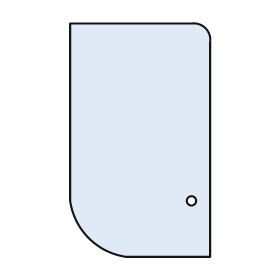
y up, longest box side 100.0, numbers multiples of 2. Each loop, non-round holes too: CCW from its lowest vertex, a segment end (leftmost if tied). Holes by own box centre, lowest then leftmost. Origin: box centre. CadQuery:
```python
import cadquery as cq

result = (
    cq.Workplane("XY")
    .moveTo(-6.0, -50.0)
    .lineTo(30.0, -50.0)
    .lineTo(30.0, 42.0)
    .threePointArc((28.0, 48.0), (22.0, 50.0))
    .lineTo(-30.0, 50.0)
    .lineTo(-30.0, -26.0)
    .threePointArc((-22.0, -42.0), (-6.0, -50.0))
    .close()
    .moveTo(22.0, -26.0)
    .circle(2.0)
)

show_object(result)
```